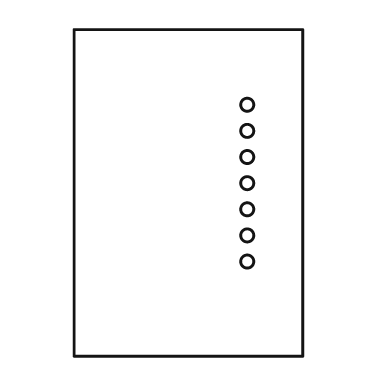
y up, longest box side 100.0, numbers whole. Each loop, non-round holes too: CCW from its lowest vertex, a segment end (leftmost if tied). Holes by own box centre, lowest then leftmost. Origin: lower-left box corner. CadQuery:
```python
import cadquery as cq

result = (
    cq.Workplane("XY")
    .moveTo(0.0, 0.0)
    .lineTo(70.0, 0.0)
    .lineTo(70.0, 100.0)
    .lineTo(0.0, 100.0)
    .close()
    .moveTo(53.0, 29.0)
    .circle(2.0)
    .moveTo(53.0, 37.0)
    .circle(2.0)
    .moveTo(53.0, 45.0)
    .circle(2.0)
    .moveTo(53.0, 53.0)
    .circle(2.0)
    .moveTo(53.0, 61.0)
    .circle(2.0)
    .moveTo(53.0, 69.0)
    .circle(2.0)
    .moveTo(53.0, 77.0)
    .circle(2.0)
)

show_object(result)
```